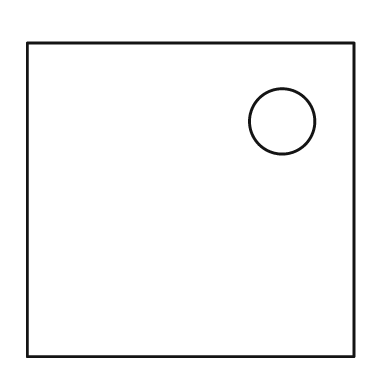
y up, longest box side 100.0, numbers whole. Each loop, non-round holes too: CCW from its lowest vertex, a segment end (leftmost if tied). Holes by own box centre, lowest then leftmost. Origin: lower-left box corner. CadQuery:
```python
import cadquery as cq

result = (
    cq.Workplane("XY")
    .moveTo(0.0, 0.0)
    .lineTo(100.0, 0.0)
    .lineTo(100.0, 96.0)
    .lineTo(0.0, 96.0)
    .close()
    .moveTo(78.0, 72.0)
    .circle(10.0)
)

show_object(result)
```